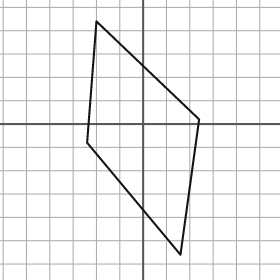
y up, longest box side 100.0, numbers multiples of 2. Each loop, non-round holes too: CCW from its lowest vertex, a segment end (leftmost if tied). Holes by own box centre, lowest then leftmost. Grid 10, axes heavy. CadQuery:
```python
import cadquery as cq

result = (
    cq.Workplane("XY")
    .moveTo(16.0, -56.0)
    .lineTo(24.0, 2.0)
    .lineTo(-20.0, 44.0)
    .lineTo(-24.0, -8.0)
    .close()
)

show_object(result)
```